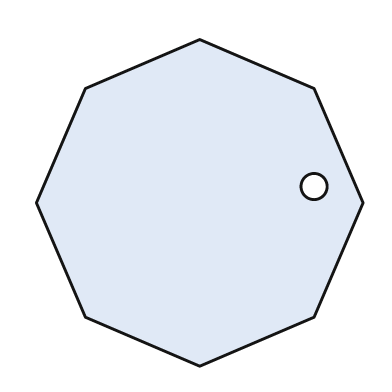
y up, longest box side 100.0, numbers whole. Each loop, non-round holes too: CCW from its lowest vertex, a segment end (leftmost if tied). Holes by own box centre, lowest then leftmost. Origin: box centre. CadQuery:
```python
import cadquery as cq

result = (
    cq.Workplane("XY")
    .moveTo(0.0, -50.0)
    .lineTo(35.0, -35.0)
    .lineTo(50.0, 0.0)
    .lineTo(35.0, 35.0)
    .lineTo(0.0, 50.0)
    .lineTo(-35.0, 35.0)
    .lineTo(-50.0, 0.0)
    .lineTo(-35.0, -35.0)
    .close()
    .moveTo(35.0, 5.0)
    .circle(4.0)
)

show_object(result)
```